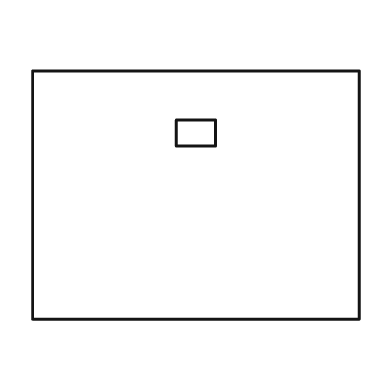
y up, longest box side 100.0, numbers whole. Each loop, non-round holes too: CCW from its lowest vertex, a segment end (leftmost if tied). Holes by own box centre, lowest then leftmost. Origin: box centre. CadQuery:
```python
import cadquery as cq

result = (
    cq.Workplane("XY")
    .moveTo(-50.0, -38.0)
    .lineTo(50.0, -38.0)
    .lineTo(50.0, 38.0)
    .lineTo(-50.0, 38.0)
    .close()
    .moveTo(-6.0, 15.0)
    .lineTo(6.0, 15.0)
    .lineTo(6.0, 23.0)
    .lineTo(-6.0, 23.0)
    .close()
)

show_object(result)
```